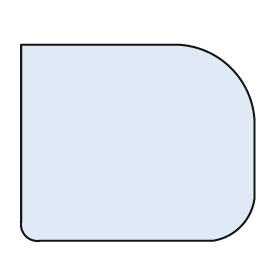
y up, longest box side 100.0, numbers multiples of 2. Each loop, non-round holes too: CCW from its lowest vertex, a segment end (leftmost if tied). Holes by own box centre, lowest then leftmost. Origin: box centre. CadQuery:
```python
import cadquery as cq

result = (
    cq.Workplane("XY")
    .moveTo(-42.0, -42.0)
    .lineTo(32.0, -42.0)
    .threePointArc((44.0, -36.0), (50.0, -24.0))
    .lineTo(50.0, 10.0)
    .threePointArc((40.0, 32.0), (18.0, 42.0))
    .lineTo(-50.0, 42.0)
    .lineTo(-50.0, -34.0)
    .threePointArc((-48.0, -40.0), (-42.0, -42.0))
    .close()
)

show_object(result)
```